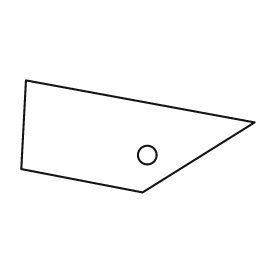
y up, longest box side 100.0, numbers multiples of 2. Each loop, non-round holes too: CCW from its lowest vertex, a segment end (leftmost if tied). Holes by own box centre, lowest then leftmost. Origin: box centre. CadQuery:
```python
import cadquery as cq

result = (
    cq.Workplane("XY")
    .moveTo(2.0, -24.0)
    .lineTo(50.0, 6.0)
    .lineTo(-48.0, 24.0)
    .lineTo(-50.0, -14.0)
    .close()
    .moveTo(4.0, -8.0)
    .circle(4.0)
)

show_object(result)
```